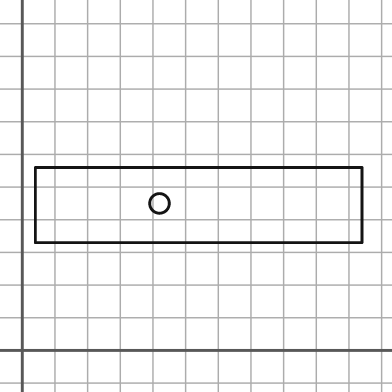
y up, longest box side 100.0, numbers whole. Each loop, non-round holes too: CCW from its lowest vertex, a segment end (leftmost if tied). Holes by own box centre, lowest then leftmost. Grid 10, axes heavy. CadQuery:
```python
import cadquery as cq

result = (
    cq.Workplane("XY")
    .moveTo(4.0, 33.0)
    .lineTo(104.0, 33.0)
    .lineTo(104.0, 56.0)
    .lineTo(4.0, 56.0)
    .close()
    .moveTo(42.0, 45.0)
    .circle(3.0)
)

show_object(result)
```